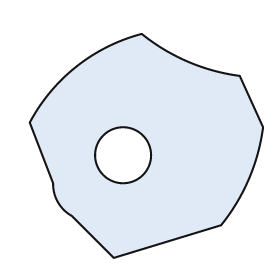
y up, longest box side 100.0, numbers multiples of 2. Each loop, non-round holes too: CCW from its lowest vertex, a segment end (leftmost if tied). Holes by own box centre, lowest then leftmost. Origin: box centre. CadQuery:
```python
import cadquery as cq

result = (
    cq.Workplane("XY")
    .moveTo(-14.0, -48.0)
    .lineTo(32.0, -34.0)
    .threePointArc((44.0, -14.0), (50.0, 8.0))
    .lineTo(40.0, 30.0)
    .threePointArc((18.0, 36.0), (-2.0, 48.0))
    .threePointArc((-30.0, 34.0), (-50.0, 10.0))
    .lineTo(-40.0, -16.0)
    .threePointArc((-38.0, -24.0), (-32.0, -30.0))
    .close()
    .moveTo(-10.0, -4.0)
    .circle(12.0)
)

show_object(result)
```